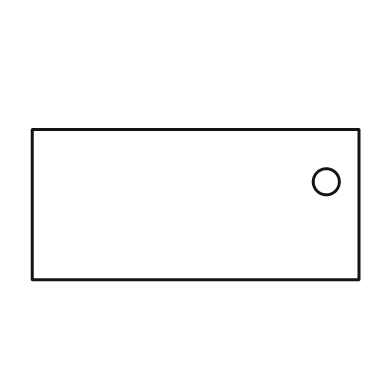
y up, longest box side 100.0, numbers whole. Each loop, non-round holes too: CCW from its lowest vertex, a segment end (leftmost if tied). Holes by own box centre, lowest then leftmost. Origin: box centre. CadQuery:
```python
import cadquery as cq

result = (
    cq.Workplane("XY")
    .moveTo(-50.0, -23.0)
    .lineTo(50.0, -23.0)
    .lineTo(50.0, 23.0)
    .lineTo(-50.0, 23.0)
    .close()
    .moveTo(40.0, 7.0)
    .circle(4.0)
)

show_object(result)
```